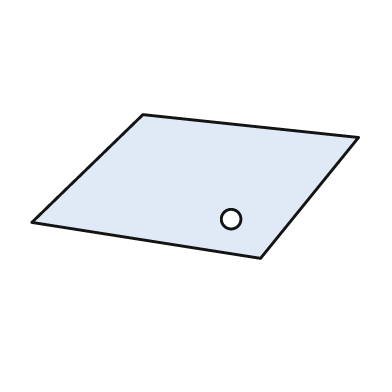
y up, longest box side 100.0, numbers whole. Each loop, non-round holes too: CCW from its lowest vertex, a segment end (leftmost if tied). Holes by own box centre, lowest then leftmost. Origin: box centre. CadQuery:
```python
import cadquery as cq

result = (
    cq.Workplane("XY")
    .moveTo(20.0, -22.0)
    .lineTo(50.0, 15.0)
    .lineTo(-16.0, 22.0)
    .lineTo(-50.0, -11.0)
    .close()
    .moveTo(11.0, -10.0)
    .circle(3.0)
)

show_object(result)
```